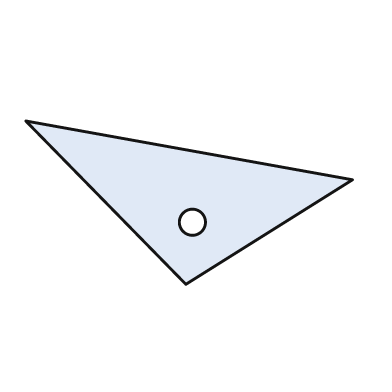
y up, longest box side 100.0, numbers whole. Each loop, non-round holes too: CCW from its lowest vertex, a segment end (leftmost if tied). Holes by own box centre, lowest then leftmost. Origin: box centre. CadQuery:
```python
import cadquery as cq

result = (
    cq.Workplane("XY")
    .moveTo(-1.0, -25.0)
    .lineTo(50.0, 7.0)
    .lineTo(-50.0, 25.0)
    .close()
    .moveTo(1.0, -6.0)
    .circle(4.0)
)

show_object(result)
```